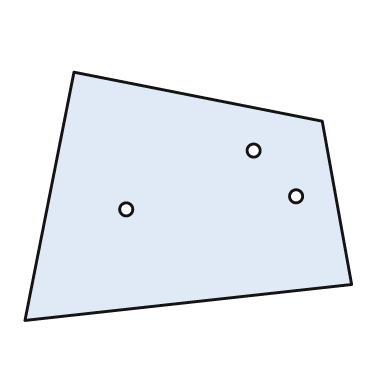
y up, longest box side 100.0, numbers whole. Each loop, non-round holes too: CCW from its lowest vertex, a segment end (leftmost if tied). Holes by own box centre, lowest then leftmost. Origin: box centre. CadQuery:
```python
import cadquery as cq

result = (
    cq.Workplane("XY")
    .moveTo(-50.0, -38.0)
    .lineTo(50.0, -27.0)
    .lineTo(41.0, 23.0)
    .lineTo(-35.0, 38.0)
    .close()
    .moveTo(-19.0, -4.0)
    .circle(2.0)
    .moveTo(33.0, 0.0)
    .circle(2.0)
    .moveTo(20.0, 14.0)
    .circle(2.0)
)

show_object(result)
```